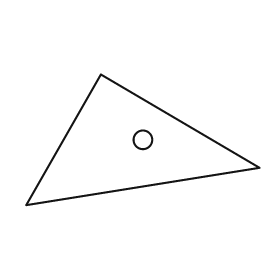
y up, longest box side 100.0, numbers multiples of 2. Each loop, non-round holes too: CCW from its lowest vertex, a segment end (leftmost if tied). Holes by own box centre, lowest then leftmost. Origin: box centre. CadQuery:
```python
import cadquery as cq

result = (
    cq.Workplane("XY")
    .moveTo(-50.0, -28.0)
    .lineTo(50.0, -12.0)
    .lineTo(-18.0, 28.0)
    .close()
    .moveTo(0.0, 0.0)
    .circle(4.0)
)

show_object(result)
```